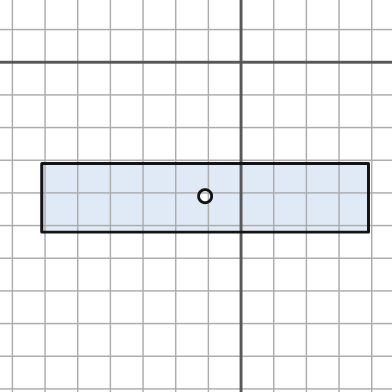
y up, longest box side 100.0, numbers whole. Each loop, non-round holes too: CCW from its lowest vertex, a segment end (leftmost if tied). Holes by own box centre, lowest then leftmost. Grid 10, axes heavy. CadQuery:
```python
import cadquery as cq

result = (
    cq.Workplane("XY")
    .moveTo(-61.0, -52.0)
    .lineTo(39.0, -52.0)
    .lineTo(39.0, -31.0)
    .lineTo(-61.0, -31.0)
    .close()
    .moveTo(-11.0, -41.0)
    .circle(2.0)
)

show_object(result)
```